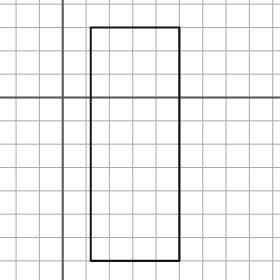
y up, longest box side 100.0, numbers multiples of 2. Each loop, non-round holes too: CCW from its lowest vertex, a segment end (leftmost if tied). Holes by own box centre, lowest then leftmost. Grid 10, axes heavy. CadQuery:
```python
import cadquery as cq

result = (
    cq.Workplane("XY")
    .moveTo(12.0, -70.0)
    .lineTo(50.0, -70.0)
    .lineTo(50.0, 30.0)
    .lineTo(12.0, 30.0)
    .close()
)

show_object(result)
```